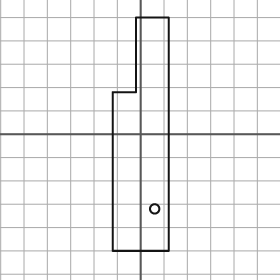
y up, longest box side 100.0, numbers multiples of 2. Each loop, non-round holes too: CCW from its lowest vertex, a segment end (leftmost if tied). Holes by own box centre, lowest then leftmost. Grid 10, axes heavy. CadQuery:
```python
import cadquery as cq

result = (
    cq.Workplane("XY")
    .moveTo(-12.0, -50.0)
    .lineTo(12.0, -50.0)
    .lineTo(12.0, 50.0)
    .lineTo(-2.0, 50.0)
    .lineTo(-2.0, 18.0)
    .lineTo(-12.0, 18.0)
    .close()
    .moveTo(6.0, -32.0)
    .circle(2.0)
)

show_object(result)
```